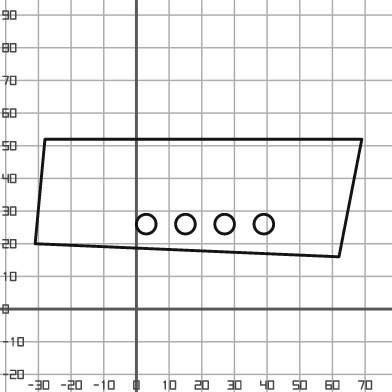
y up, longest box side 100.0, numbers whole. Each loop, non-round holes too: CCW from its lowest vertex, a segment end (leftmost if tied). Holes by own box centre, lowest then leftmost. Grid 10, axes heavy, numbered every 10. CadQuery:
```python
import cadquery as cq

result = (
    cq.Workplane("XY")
    .moveTo(62.0, 16.0)
    .lineTo(69.0, 52.0)
    .lineTo(-28.0, 52.0)
    .lineTo(-31.0, 20.0)
    .close()
    .moveTo(3.0, 26.0)
    .circle(3.0)
    .moveTo(15.0, 26.0)
    .circle(3.0)
    .moveTo(27.0, 26.0)
    .circle(3.0)
    .moveTo(39.0, 26.0)
    .circle(3.0)
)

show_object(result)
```